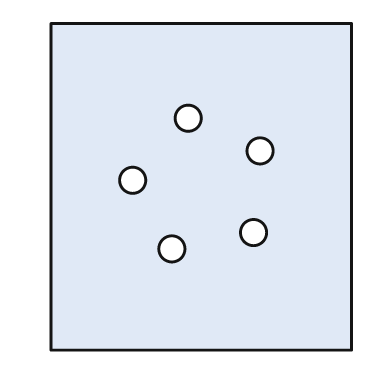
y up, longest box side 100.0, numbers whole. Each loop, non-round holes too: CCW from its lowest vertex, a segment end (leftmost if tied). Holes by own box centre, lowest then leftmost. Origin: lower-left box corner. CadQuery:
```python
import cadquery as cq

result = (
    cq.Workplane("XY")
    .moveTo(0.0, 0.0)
    .lineTo(92.0, 0.0)
    .lineTo(92.0, 100.0)
    .lineTo(0.0, 100.0)
    .close()
    .moveTo(37.0, 31.0)
    .circle(4.0)
    .moveTo(62.0, 36.0)
    .circle(4.0)
    .moveTo(25.0, 52.0)
    .circle(4.0)
    .moveTo(64.0, 61.0)
    .circle(4.0)
    .moveTo(42.0, 71.0)
    .circle(4.0)
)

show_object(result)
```